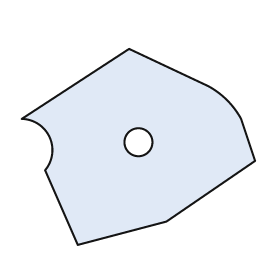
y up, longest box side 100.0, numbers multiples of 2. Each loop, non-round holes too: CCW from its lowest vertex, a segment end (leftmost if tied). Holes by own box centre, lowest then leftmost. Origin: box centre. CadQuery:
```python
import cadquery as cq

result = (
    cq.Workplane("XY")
    .moveTo(-26.0, -42.0)
    .lineTo(12.0, -32.0)
    .lineTo(50.0, -6.0)
    .lineTo(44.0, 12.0)
    .threePointArc((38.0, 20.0), (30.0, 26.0))
    .lineTo(-4.0, 42.0)
    .lineTo(-50.0, 12.0)
    .threePointArc((-38.0, 4.0), (-40.0, -10.0))
    .close()
    .moveTo(0.0, 2.0)
    .circle(6.0)
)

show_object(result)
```